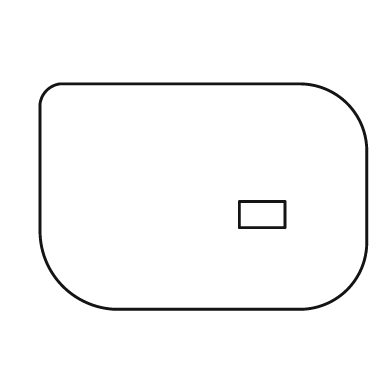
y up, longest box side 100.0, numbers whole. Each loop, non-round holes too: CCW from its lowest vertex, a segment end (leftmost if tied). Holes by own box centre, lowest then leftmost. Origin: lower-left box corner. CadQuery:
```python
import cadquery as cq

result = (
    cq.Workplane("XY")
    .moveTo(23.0, 0.0)
    .lineTo(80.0, 0.0)
    .threePointArc((94.0, 6.0), (100.0, 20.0))
    .lineTo(100.0, 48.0)
    .threePointArc((94.0, 63.0), (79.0, 69.0))
    .lineTo(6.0, 69.0)
    .threePointArc((2.0, 67.0), (0.0, 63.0))
    .lineTo(0.0, 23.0)
    .threePointArc((7.0, 7.0), (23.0, 0.0))
    .close()
    .moveTo(61.0, 25.0)
    .lineTo(75.0, 25.0)
    .lineTo(75.0, 33.0)
    .lineTo(61.0, 33.0)
    .close()
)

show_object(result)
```